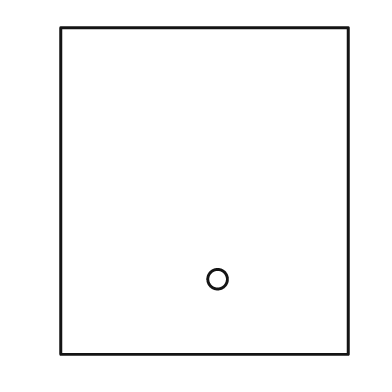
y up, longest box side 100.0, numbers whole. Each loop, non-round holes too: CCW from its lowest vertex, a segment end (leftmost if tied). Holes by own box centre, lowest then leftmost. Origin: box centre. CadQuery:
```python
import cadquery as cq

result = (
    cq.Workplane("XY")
    .moveTo(-44.0, -50.0)
    .lineTo(44.0, -50.0)
    .lineTo(44.0, 50.0)
    .lineTo(-44.0, 50.0)
    .close()
    .moveTo(4.0, -27.0)
    .circle(3.0)
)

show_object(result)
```